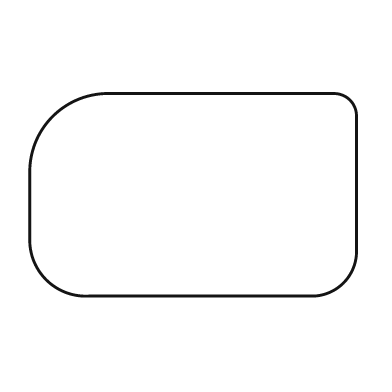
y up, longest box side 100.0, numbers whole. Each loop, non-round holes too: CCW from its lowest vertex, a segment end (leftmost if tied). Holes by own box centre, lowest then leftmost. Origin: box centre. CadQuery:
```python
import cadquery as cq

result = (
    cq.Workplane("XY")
    .moveTo(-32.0, -31.0)
    .lineTo(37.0, -31.0)
    .threePointArc((46.0, -27.0), (50.0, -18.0))
    .lineTo(50.0, 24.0)
    .threePointArc((48.0, 29.0), (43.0, 31.0))
    .lineTo(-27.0, 31.0)
    .threePointArc((-43.0, 24.0), (-50.0, 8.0))
    .lineTo(-50.0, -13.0)
    .threePointArc((-45.0, -26.0), (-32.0, -31.0))
    .close()
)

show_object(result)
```